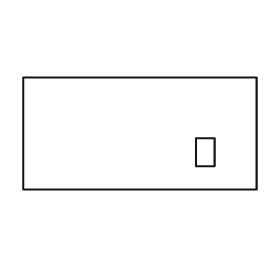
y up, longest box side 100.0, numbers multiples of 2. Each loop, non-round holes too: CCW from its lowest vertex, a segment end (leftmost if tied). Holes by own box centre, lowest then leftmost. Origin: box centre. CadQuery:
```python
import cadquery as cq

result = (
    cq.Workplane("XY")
    .moveTo(-50.0, -24.0)
    .lineTo(50.0, -24.0)
    .lineTo(50.0, 24.0)
    .lineTo(-50.0, 24.0)
    .close()
    .moveTo(24.0, -14.0)
    .lineTo(32.0, -14.0)
    .lineTo(32.0, -2.0)
    .lineTo(24.0, -2.0)
    .close()
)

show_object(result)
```